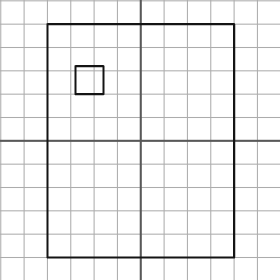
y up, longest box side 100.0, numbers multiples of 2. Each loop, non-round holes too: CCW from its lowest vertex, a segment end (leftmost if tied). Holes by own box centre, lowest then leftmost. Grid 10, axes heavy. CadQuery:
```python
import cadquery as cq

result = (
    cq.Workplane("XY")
    .moveTo(-40.0, -50.0)
    .lineTo(40.0, -50.0)
    .lineTo(40.0, 50.0)
    .lineTo(-40.0, 50.0)
    .close()
    .moveTo(-28.0, 20.0)
    .lineTo(-16.0, 20.0)
    .lineTo(-16.0, 32.0)
    .lineTo(-28.0, 32.0)
    .close()
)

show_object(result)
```